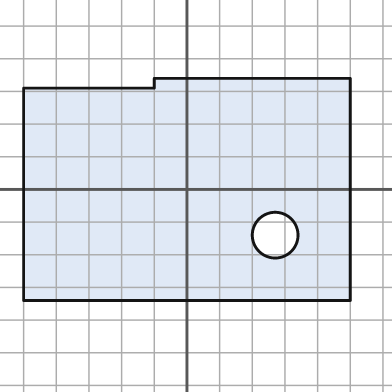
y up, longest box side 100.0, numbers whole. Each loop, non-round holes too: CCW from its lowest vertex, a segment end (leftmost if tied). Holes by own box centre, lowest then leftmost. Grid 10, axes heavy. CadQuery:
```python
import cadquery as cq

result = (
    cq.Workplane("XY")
    .moveTo(-50.0, -34.0)
    .lineTo(50.0, -34.0)
    .lineTo(50.0, 34.0)
    .lineTo(-10.0, 34.0)
    .lineTo(-10.0, 31.0)
    .lineTo(-50.0, 31.0)
    .close()
    .moveTo(27.0, -14.0)
    .circle(7.0)
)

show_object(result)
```